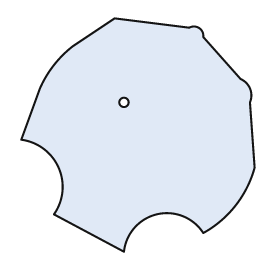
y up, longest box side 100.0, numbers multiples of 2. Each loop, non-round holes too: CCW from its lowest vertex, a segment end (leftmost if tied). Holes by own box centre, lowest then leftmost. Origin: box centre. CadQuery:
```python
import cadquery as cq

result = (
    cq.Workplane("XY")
    .moveTo(-6.0, -50.0)
    .threePointArc((8.0, -34.0), (28.0, -42.0))
    .threePointArc((42.0, -30.0), (50.0, -14.0))
    .lineTo(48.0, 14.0)
    .threePointArc((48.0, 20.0), (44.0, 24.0))
    .lineTo(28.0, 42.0)
    .threePointArc((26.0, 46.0), (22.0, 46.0))
    .lineTo(-10.0, 50.0)
    .lineTo(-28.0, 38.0)
    .threePointArc((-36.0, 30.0), (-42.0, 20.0))
    .lineTo(-50.0, -2.0)
    .threePointArc((-34.0, -14.0), (-36.0, -34.0))
    .close()
    .moveTo(-6.0, 14.0)
    .circle(2.0)
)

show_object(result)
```